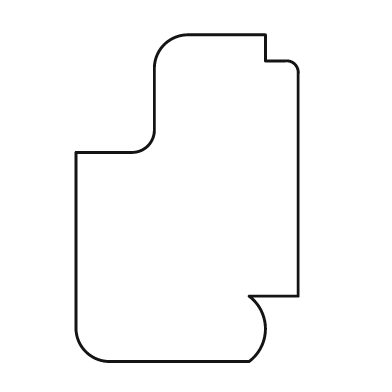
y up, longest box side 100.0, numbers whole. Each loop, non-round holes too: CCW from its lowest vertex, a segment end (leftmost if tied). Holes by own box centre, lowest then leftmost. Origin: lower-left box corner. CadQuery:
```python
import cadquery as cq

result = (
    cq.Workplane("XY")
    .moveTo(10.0, 0.0)
    .lineTo(53.0, 0.0)
    .threePointArc((58.0, 10.0), (53.0, 20.0))
    .lineTo(68.0, 20.0)
    .lineTo(68.0, 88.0)
    .threePointArc((67.0, 91.0), (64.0, 92.0))
    .lineTo(58.0, 92.0)
    .lineTo(58.0, 100.0)
    .lineTo(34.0, 100.0)
    .threePointArc((27.0, 97.0), (24.0, 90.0))
    .lineTo(24.0, 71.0)
    .threePointArc((22.0, 66.0), (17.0, 64.0))
    .lineTo(0.0, 64.0)
    .lineTo(0.0, 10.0)
    .threePointArc((3.0, 3.0), (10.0, 0.0))
    .close()
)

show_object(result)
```